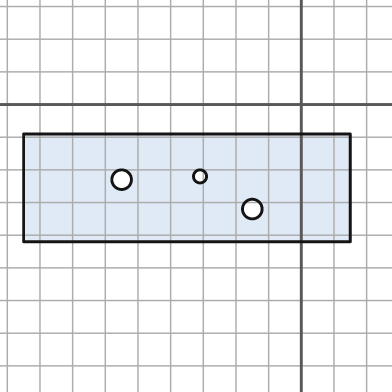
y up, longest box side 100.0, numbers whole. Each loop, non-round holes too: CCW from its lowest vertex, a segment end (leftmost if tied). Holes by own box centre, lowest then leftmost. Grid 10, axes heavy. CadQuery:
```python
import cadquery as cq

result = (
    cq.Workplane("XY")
    .moveTo(-85.0, -42.0)
    .lineTo(15.0, -42.0)
    .lineTo(15.0, -9.0)
    .lineTo(-85.0, -9.0)
    .close()
    .moveTo(-15.0, -32.0)
    .circle(3.0)
    .moveTo(-55.0, -23.0)
    .circle(3.0)
    .moveTo(-31.0, -22.0)
    .circle(2.0)
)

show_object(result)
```